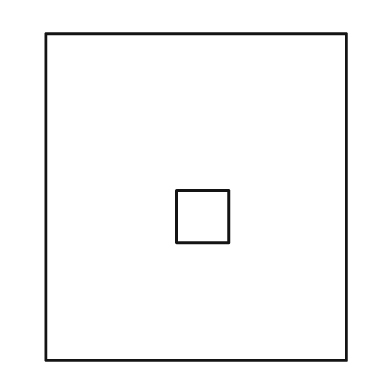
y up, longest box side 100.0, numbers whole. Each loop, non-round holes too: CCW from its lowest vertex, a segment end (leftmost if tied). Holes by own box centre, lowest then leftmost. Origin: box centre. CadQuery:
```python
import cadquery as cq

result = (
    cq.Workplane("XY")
    .moveTo(-46.0, -50.0)
    .lineTo(46.0, -50.0)
    .lineTo(46.0, 50.0)
    .lineTo(-46.0, 50.0)
    .close()
    .moveTo(-6.0, -14.0)
    .lineTo(10.0, -14.0)
    .lineTo(10.0, 2.0)
    .lineTo(-6.0, 2.0)
    .close()
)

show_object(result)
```